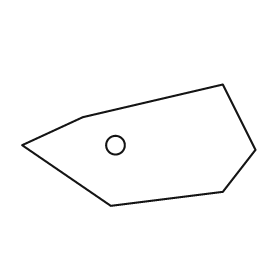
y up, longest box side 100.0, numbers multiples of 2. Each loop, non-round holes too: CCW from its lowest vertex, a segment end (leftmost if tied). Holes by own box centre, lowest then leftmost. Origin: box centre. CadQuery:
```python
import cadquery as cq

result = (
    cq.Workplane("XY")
    .moveTo(-12.0, -26.0)
    .lineTo(36.0, -20.0)
    .lineTo(50.0, -2.0)
    .lineTo(36.0, 26.0)
    .lineTo(-24.0, 12.0)
    .lineTo(-50.0, 0.0)
    .close()
    .moveTo(-10.0, 0.0)
    .circle(4.0)
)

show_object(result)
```